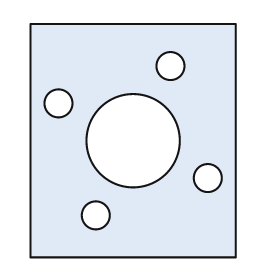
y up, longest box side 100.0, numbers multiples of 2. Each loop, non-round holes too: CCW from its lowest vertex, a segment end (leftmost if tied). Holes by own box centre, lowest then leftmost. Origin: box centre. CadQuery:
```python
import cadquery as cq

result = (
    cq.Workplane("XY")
    .moveTo(-44.0, -50.0)
    .lineTo(44.0, -50.0)
    .lineTo(44.0, 50.0)
    .lineTo(-44.0, 50.0)
    .close()
    .moveTo(-16.0, -32.0)
    .circle(6.0)
    .moveTo(32.0, -16.0)
    .circle(6.0)
    .moveTo(0.0, 0.0)
    .circle(20.0)
    .moveTo(-32.0, 16.0)
    .circle(6.0)
    .moveTo(16.0, 32.0)
    .circle(6.0)
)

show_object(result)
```